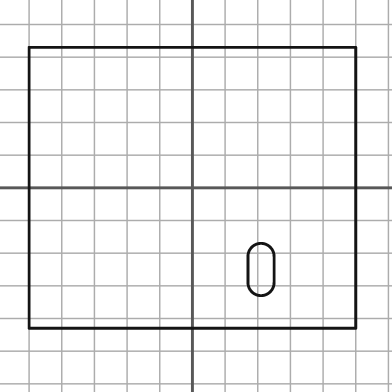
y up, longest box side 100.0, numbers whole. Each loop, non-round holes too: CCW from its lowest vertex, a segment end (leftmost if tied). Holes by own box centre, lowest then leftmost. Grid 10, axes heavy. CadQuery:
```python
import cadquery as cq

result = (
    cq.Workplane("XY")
    .moveTo(-50.0, -43.0)
    .lineTo(50.0, -43.0)
    .lineTo(50.0, 43.0)
    .lineTo(-50.0, 43.0)
    .close()
    .moveTo(17.0, -29.0)
    .threePointArc((21.0, -33.0), (25.0, -29.0))
    .lineTo(25.0, -21.0)
    .threePointArc((21.0, -17.0), (17.0, -21.0))
    .close()
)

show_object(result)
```